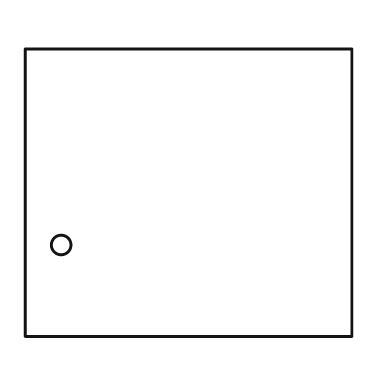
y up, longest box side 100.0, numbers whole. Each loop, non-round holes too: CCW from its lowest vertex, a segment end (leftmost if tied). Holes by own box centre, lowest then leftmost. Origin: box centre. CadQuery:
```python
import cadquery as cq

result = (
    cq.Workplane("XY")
    .moveTo(-50.0, -44.0)
    .lineTo(50.0, -44.0)
    .lineTo(50.0, 44.0)
    .lineTo(-50.0, 44.0)
    .close()
    .moveTo(-39.0, -16.0)
    .circle(3.0)
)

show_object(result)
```